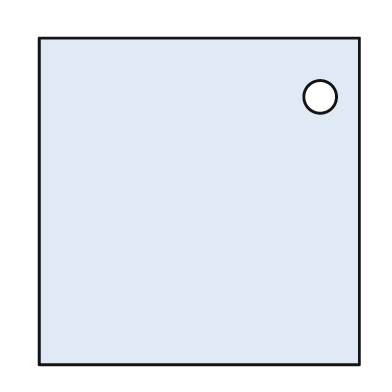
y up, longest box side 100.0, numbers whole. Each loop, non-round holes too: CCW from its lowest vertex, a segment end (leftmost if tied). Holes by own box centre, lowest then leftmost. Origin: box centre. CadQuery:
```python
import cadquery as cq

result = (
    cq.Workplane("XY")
    .moveTo(-49.0, -50.0)
    .lineTo(49.0, -50.0)
    .lineTo(49.0, 50.0)
    .lineTo(-49.0, 50.0)
    .close()
    .moveTo(37.0, 32.0)
    .circle(5.0)
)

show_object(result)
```